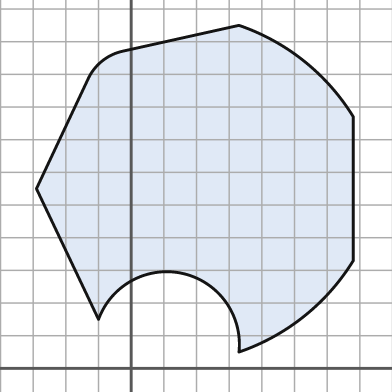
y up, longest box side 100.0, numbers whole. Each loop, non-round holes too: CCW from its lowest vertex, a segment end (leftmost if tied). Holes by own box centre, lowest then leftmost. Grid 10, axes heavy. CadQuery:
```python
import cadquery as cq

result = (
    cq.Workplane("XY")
    .moveTo(33.0, 5.0)
    .threePointArc((53.0, 16.0), (68.0, 33.0))
    .lineTo(68.0, 77.0)
    .threePointArc((53.0, 94.0), (33.0, 105.0))
    .lineTo(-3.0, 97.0)
    .threePointArc((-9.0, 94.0), (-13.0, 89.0))
    .lineTo(-29.0, 55.0)
    .lineTo(-10.0, 15.0)
    .threePointArc((16.0, 29.0), (33.0, 5.0))
    .close()
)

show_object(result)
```